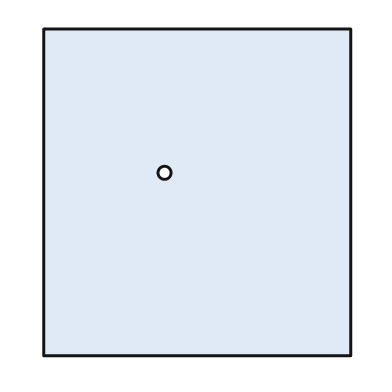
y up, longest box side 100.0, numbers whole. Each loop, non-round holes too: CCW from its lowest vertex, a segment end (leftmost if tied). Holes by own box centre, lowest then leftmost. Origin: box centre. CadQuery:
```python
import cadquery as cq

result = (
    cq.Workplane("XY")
    .moveTo(-47.0, -50.0)
    .lineTo(47.0, -50.0)
    .lineTo(47.0, 50.0)
    .lineTo(-47.0, 50.0)
    .close()
    .moveTo(-10.0, 6.0)
    .circle(2.0)
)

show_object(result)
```